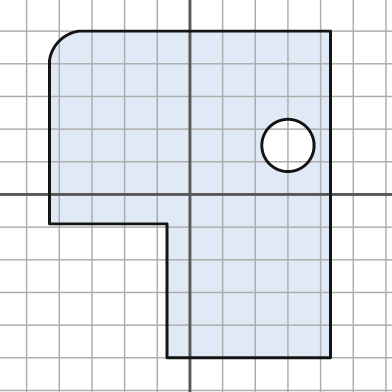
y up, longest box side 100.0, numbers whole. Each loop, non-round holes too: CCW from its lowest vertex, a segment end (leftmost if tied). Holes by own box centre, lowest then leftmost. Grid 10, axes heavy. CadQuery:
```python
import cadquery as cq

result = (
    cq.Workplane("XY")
    .moveTo(-7.0, -50.0)
    .lineTo(43.0, -50.0)
    .lineTo(43.0, 50.0)
    .lineTo(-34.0, 50.0)
    .threePointArc((-40.0, 47.0), (-43.0, 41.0))
    .lineTo(-43.0, -9.0)
    .lineTo(-7.0, -9.0)
    .close()
    .moveTo(30.0, 15.0)
    .circle(8.0)
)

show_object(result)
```